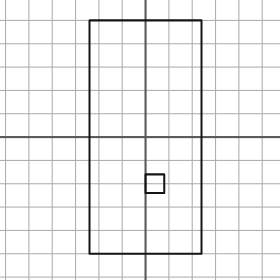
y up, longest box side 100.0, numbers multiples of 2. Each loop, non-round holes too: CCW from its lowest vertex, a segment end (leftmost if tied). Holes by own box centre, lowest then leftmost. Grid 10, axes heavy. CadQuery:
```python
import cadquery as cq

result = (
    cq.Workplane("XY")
    .moveTo(-24.0, -50.0)
    .lineTo(24.0, -50.0)
    .lineTo(24.0, 50.0)
    .lineTo(-24.0, 50.0)
    .close()
    .moveTo(0.0, -24.0)
    .lineTo(8.0, -24.0)
    .lineTo(8.0, -16.0)
    .lineTo(0.0, -16.0)
    .close()
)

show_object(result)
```